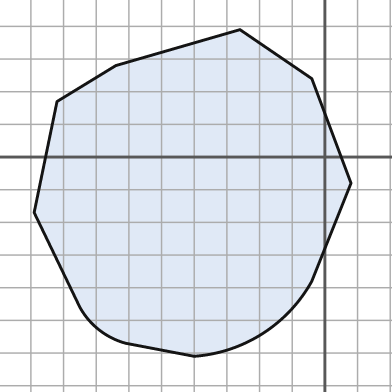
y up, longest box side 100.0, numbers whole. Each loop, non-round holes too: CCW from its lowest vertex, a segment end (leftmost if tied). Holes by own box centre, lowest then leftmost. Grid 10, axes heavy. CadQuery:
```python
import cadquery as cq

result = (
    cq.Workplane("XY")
    .moveTo(-40.0, -61.0)
    .threePointArc((-19.0, -54.0), (-4.0, -38.0))
    .lineTo(8.0, -8.0)
    .lineTo(-4.0, 24.0)
    .lineTo(-26.0, 39.0)
    .lineTo(-64.0, 28.0)
    .lineTo(-82.0, 17.0)
    .lineTo(-89.0, -17.0)
    .lineTo(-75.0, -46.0)
    .threePointArc((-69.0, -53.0), (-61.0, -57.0))
    .close()
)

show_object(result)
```